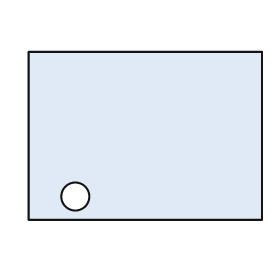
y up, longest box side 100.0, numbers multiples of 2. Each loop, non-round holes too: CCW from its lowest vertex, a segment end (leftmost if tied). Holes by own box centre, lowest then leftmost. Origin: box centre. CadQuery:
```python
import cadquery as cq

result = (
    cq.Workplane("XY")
    .moveTo(-50.0, -36.0)
    .lineTo(50.0, -36.0)
    .lineTo(50.0, 36.0)
    .lineTo(-50.0, 36.0)
    .close()
    .moveTo(-30.0, -26.0)
    .circle(6.0)
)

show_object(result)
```